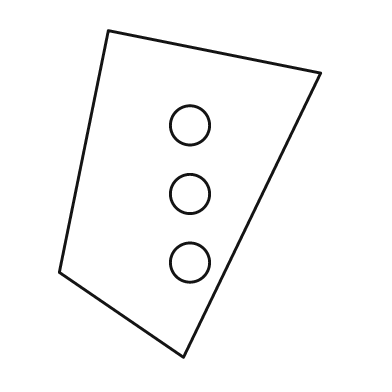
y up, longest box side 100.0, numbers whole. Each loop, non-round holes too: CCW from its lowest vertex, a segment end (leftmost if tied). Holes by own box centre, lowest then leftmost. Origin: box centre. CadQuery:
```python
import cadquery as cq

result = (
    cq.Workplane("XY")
    .moveTo(-2.0, -50.0)
    .lineTo(40.0, 37.0)
    .lineTo(-25.0, 50.0)
    .lineTo(-40.0, -24.0)
    .close()
    .moveTo(0.0, -21.0)
    .circle(6.0)
    .moveTo(0.0, 0.0)
    .circle(6.0)
    .moveTo(0.0, 21.0)
    .circle(6.0)
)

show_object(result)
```